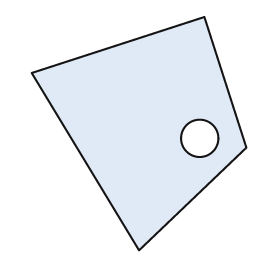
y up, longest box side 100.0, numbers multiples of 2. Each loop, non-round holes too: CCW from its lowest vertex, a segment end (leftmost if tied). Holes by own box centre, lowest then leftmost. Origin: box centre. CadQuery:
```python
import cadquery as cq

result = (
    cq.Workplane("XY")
    .moveTo(0.0, -50.0)
    .lineTo(46.0, -6.0)
    .lineTo(28.0, 50.0)
    .lineTo(-46.0, 26.0)
    .close()
    .moveTo(26.0, -2.0)
    .circle(8.0)
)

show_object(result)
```